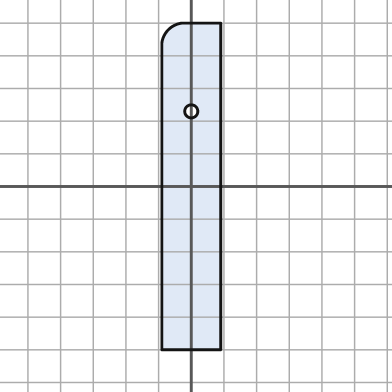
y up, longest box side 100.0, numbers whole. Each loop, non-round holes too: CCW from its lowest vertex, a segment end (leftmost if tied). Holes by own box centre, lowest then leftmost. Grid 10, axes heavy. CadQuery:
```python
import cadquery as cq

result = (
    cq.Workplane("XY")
    .moveTo(-9.0, -50.0)
    .lineTo(9.0, -50.0)
    .lineTo(9.0, 50.0)
    .lineTo(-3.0, 50.0)
    .threePointArc((-7.0, 48.0), (-9.0, 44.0))
    .close()
    .moveTo(0.0, 23.0)
    .circle(2.0)
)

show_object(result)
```